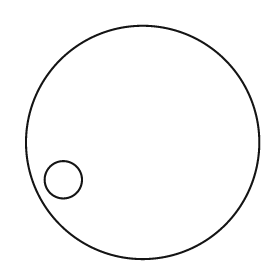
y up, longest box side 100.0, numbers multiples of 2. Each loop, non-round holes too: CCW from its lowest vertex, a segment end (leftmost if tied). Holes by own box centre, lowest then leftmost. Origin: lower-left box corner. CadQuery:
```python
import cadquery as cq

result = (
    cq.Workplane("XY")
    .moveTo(50.0, 50.0)
    .circle(50.0)
    .moveTo(16.0, 34.0)
    .circle(8.0)
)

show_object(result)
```